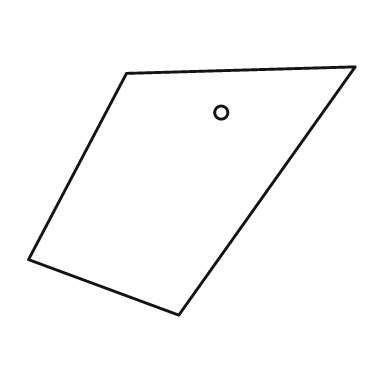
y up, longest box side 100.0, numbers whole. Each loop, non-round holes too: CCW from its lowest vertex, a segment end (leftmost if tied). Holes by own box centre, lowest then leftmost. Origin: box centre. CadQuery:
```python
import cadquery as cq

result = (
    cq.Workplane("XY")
    .moveTo(-4.0, -38.0)
    .lineTo(50.0, 38.0)
    .lineTo(-20.0, 36.0)
    .lineTo(-50.0, -21.0)
    .close()
    .moveTo(9.0, 24.0)
    .circle(2.0)
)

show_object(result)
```